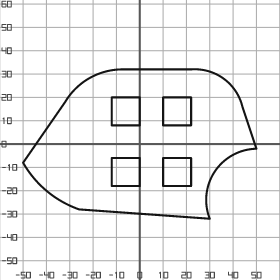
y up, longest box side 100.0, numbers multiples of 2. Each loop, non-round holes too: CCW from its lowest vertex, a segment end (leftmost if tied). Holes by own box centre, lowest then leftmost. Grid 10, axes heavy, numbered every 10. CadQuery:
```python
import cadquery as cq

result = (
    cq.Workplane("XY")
    .moveTo(30.0, -32.0)
    .threePointArc((32.0, -12.0), (50.0, -2.0))
    .lineTo(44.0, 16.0)
    .threePointArc((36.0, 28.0), (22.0, 32.0))
    .lineTo(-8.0, 32.0)
    .threePointArc((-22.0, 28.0), (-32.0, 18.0))
    .lineTo(-50.0, -8.0)
    .threePointArc((-40.0, -20.0), (-26.0, -28.0))
    .close()
    .moveTo(-12.0, -18.0)
    .lineTo(0.0, -18.0)
    .lineTo(0.0, -6.0)
    .lineTo(-12.0, -6.0)
    .close()
    .moveTo(10.0, -18.0)
    .lineTo(22.0, -18.0)
    .lineTo(22.0, -6.0)
    .lineTo(10.0, -6.0)
    .close()
    .moveTo(-12.0, 8.0)
    .lineTo(0.0, 8.0)
    .lineTo(0.0, 20.0)
    .lineTo(-12.0, 20.0)
    .close()
    .moveTo(10.0, 8.0)
    .lineTo(22.0, 8.0)
    .lineTo(22.0, 20.0)
    .lineTo(10.0, 20.0)
    .close()
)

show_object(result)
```